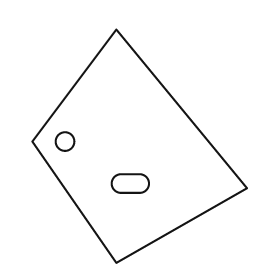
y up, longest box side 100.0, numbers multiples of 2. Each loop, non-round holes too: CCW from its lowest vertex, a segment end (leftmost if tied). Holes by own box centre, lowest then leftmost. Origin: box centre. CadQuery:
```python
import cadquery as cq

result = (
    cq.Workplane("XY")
    .moveTo(-10.0, -50.0)
    .lineTo(46.0, -18.0)
    .lineTo(-10.0, 50.0)
    .lineTo(-46.0, 2.0)
    .close()
    .moveTo(-8.0, -20.0)
    .lineTo(0.0, -20.0)
    .threePointArc((4.0, -16.0), (0.0, -12.0))
    .lineTo(-8.0, -12.0)
    .threePointArc((-12.0, -16.0), (-8.0, -20.0))
    .close()
    .moveTo(-32.0, 2.0)
    .circle(4.0)
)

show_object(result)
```